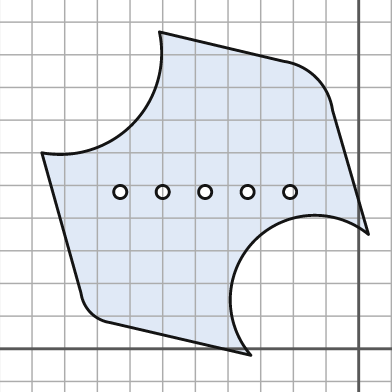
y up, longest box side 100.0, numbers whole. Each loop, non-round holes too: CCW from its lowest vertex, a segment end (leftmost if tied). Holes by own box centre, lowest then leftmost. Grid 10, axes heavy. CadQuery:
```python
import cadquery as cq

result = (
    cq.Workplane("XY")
    .moveTo(-33.0, -2.0)
    .threePointArc((-32.0, 33.0), (3.0, 35.0))
    .lineTo(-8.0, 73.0)
    .threePointArc((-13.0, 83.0), (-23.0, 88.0))
    .lineTo(-61.0, 97.0)
    .threePointArc((-69.0, 69.0), (-97.0, 60.0))
    .lineTo(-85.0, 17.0)
    .threePointArc((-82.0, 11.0), (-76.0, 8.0))
    .close()
    .moveTo(-73.0, 48.0)
    .circle(2.0)
    .moveTo(-60.0, 48.0)
    .circle(2.0)
    .moveTo(-47.0, 48.0)
    .circle(2.0)
    .moveTo(-34.0, 48.0)
    .circle(2.0)
    .moveTo(-21.0, 48.0)
    .circle(2.0)
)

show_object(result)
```